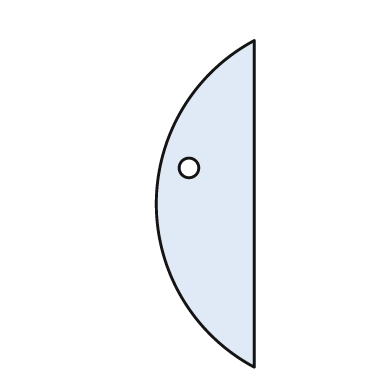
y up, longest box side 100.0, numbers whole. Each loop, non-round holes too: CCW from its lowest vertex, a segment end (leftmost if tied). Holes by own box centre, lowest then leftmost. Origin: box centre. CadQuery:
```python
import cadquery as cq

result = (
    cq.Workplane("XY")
    .moveTo(15.0, -50.0)
    .lineTo(15.0, 50.0)
    .threePointArc((-15.0, 0.0), (15.0, -50.0))
    .close()
    .moveTo(-5.0, 11.0)
    .circle(3.0)
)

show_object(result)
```